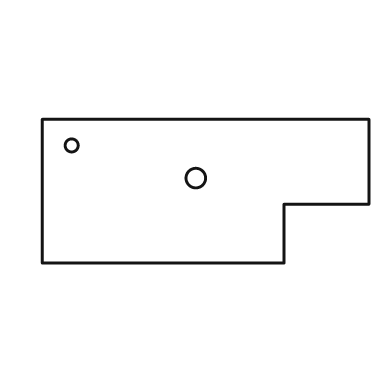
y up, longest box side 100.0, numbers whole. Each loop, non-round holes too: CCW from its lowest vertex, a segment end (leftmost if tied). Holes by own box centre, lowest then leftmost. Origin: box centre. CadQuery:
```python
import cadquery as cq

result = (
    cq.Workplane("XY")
    .moveTo(-50.0, -22.0)
    .lineTo(24.0, -22.0)
    .lineTo(24.0, -4.0)
    .lineTo(50.0, -4.0)
    .lineTo(50.0, 22.0)
    .lineTo(-50.0, 22.0)
    .close()
    .moveTo(-3.0, 4.0)
    .circle(3.0)
    .moveTo(-41.0, 14.0)
    .circle(2.0)
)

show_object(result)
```